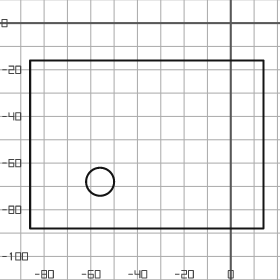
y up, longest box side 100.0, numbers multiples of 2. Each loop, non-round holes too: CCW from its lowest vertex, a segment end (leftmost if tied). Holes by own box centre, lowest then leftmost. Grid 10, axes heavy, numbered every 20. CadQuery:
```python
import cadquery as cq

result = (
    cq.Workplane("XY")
    .moveTo(-86.0, -88.0)
    .lineTo(14.0, -88.0)
    .lineTo(14.0, -16.0)
    .lineTo(-86.0, -16.0)
    .close()
    .moveTo(-56.0, -68.0)
    .circle(6.0)
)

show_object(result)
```